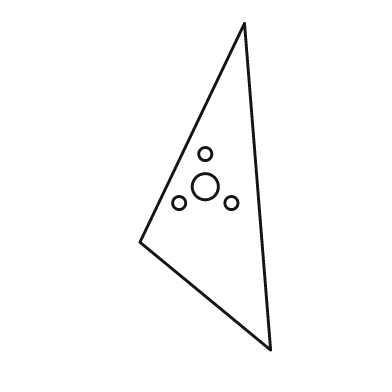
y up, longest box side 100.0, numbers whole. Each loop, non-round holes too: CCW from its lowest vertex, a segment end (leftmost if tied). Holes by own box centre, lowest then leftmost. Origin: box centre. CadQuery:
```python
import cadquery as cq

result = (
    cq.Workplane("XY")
    .moveTo(20.0, -50.0)
    .lineTo(12.0, 50.0)
    .lineTo(-20.0, -17.0)
    .close()
    .moveTo(-8.0, -5.0)
    .circle(2.0)
    .moveTo(8.0, -5.0)
    .circle(2.0)
    .moveTo(0.0, 0.0)
    .circle(4.0)
    .moveTo(0.0, 10.0)
    .circle(2.0)
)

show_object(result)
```